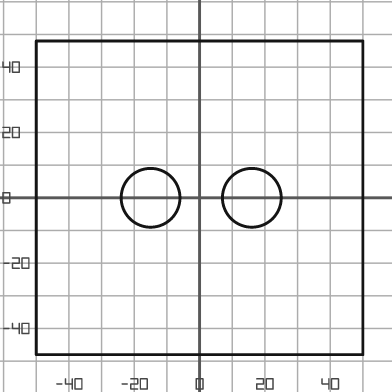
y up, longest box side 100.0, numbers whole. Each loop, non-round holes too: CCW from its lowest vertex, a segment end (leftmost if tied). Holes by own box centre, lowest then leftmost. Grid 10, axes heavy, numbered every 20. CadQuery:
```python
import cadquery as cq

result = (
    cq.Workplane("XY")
    .moveTo(-50.0, -48.0)
    .lineTo(50.0, -48.0)
    .lineTo(50.0, 48.0)
    .lineTo(-50.0, 48.0)
    .close()
    .moveTo(-15.0, 0.0)
    .circle(9.0)
    .moveTo(16.0, 0.0)
    .circle(9.0)
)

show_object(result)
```